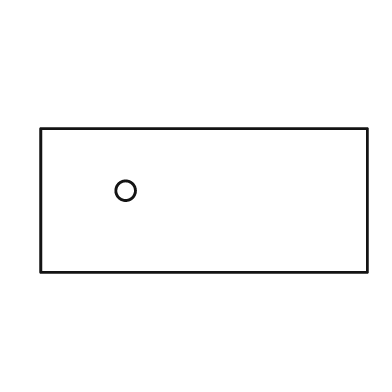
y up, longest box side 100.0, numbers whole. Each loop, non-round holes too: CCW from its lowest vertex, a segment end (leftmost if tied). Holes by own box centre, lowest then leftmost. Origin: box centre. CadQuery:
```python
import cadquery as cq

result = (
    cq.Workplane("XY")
    .moveTo(-50.0, -22.0)
    .lineTo(50.0, -22.0)
    .lineTo(50.0, 22.0)
    .lineTo(-50.0, 22.0)
    .close()
    .moveTo(-24.0, 3.0)
    .circle(3.0)
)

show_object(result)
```